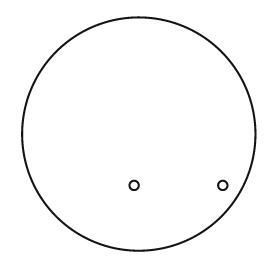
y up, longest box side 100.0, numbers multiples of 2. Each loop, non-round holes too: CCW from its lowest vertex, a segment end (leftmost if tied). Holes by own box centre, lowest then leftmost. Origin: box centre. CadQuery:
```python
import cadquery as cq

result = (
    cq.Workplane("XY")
    .moveTo(0.0, 0.0)
    .circle(50.0)
    .moveTo(-2.0, -22.0)
    .circle(2.0)
    .moveTo(36.0, -22.0)
    .circle(2.0)
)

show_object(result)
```